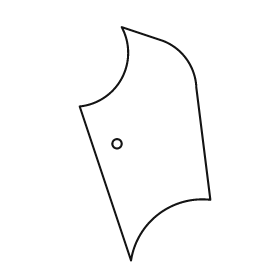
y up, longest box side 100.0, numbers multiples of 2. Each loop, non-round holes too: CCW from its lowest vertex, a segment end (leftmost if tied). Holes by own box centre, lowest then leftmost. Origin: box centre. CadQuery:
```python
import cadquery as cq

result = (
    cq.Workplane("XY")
    .moveTo(-6.0, -50.0)
    .threePointArc((6.0, -30.0), (28.0, -24.0))
    .lineTo(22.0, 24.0)
    .threePointArc((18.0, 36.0), (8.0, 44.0))
    .lineTo(-10.0, 50.0)
    .threePointArc((-10.0, 28.0), (-28.0, 16.0))
    .close()
    .moveTo(-12.0, 0.0)
    .circle(2.0)
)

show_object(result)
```